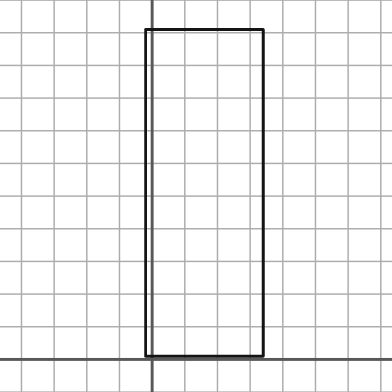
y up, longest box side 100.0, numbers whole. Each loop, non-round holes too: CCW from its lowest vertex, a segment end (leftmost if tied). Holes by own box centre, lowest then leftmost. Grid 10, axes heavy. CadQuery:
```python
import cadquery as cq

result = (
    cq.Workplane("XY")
    .moveTo(-2.0, 1.0)
    .lineTo(34.0, 1.0)
    .lineTo(34.0, 101.0)
    .lineTo(-2.0, 101.0)
    .close()
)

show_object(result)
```